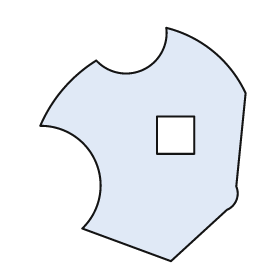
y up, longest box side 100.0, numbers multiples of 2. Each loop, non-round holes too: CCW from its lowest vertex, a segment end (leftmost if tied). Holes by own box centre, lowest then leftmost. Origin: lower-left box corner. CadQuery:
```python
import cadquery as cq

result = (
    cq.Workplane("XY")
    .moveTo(56.0, 0.0)
    .lineTo(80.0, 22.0)
    .threePointArc((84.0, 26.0), (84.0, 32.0))
    .lineTo(88.0, 72.0)
    .threePointArc((74.0, 90.0), (54.0, 100.0))
    .threePointArc((44.0, 82.0), (24.0, 86.0))
    .threePointArc((10.0, 74.0), (0.0, 58.0))
    .threePointArc((24.0, 42.0), (18.0, 14.0))
    .close()
    .moveTo(50.0, 46.0)
    .lineTo(66.0, 46.0)
    .lineTo(66.0, 62.0)
    .lineTo(50.0, 62.0)
    .close()
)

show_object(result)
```